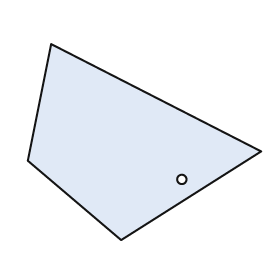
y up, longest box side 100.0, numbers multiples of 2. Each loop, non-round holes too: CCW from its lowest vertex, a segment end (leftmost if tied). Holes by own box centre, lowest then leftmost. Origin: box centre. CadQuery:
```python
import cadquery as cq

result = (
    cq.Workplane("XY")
    .moveTo(-10.0, -42.0)
    .lineTo(50.0, -4.0)
    .lineTo(-40.0, 42.0)
    .lineTo(-50.0, -8.0)
    .close()
    .moveTo(16.0, -16.0)
    .circle(2.0)
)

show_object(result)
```